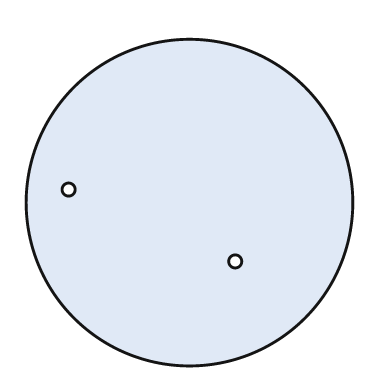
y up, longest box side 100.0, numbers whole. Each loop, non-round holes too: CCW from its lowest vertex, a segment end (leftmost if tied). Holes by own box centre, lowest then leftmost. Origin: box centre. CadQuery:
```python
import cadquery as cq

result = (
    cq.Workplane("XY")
    .moveTo(0.0, 0.0)
    .circle(50.0)
    .moveTo(14.0, -18.0)
    .circle(2.0)
    .moveTo(-37.0, 4.0)
    .circle(2.0)
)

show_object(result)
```